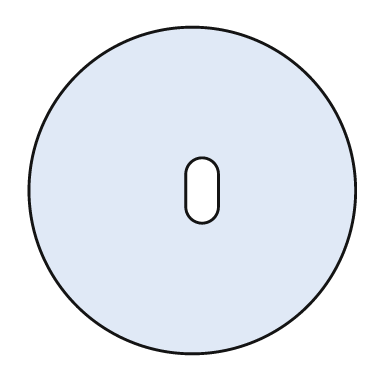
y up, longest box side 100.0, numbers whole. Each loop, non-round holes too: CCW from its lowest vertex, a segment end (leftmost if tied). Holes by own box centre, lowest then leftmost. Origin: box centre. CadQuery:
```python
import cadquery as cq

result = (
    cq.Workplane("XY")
    .moveTo(0.0, 0.0)
    .circle(50.0)
    .moveTo(-2.0, -5.0)
    .threePointArc((3.0, -10.0), (8.0, -5.0))
    .lineTo(8.0, 5.0)
    .threePointArc((3.0, 10.0), (-2.0, 5.0))
    .close()
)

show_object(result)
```